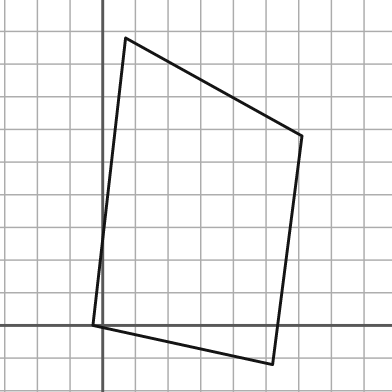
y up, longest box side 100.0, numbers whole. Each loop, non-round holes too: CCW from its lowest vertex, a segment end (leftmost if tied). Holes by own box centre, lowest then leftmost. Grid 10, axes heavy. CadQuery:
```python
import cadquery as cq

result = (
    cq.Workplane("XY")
    .moveTo(52.0, -12.0)
    .lineTo(61.0, 58.0)
    .lineTo(7.0, 88.0)
    .lineTo(-3.0, 0.0)
    .close()
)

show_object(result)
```